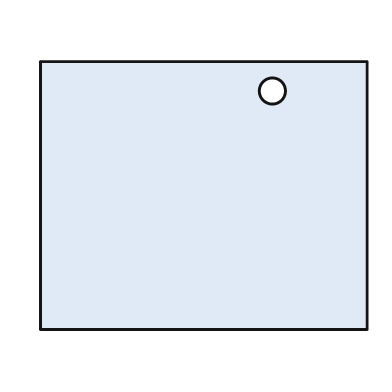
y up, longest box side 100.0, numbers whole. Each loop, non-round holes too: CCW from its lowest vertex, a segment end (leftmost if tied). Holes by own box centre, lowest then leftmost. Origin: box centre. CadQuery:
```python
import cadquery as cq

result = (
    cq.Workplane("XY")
    .moveTo(-50.0, -41.0)
    .lineTo(50.0, -41.0)
    .lineTo(50.0, 41.0)
    .lineTo(-50.0, 41.0)
    .close()
    .moveTo(21.0, 32.0)
    .circle(4.0)
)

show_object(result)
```